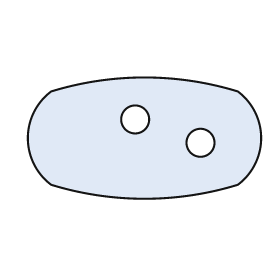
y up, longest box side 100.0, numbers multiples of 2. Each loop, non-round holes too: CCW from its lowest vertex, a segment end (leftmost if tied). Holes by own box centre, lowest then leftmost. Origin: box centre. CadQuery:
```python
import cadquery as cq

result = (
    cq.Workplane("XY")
    .moveTo(-40.0, -20.0)
    .threePointArc((0.0, -26.0), (40.0, -20.0))
    .threePointArc((50.0, 0.0), (40.0, 20.0))
    .threePointArc((0.0, 26.0), (-40.0, 20.0))
    .threePointArc((-50.0, 0.0), (-40.0, -20.0))
    .close()
    .moveTo(24.0, -2.0)
    .circle(6.0)
    .moveTo(-4.0, 8.0)
    .circle(6.0)
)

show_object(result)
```